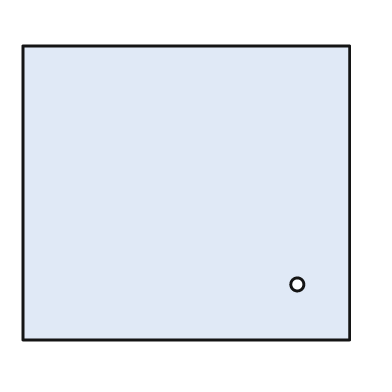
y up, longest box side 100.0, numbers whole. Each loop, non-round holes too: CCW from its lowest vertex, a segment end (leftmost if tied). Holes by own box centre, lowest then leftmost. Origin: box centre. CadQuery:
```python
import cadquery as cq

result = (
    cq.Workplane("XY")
    .moveTo(-50.0, -45.0)
    .lineTo(50.0, -45.0)
    .lineTo(50.0, 45.0)
    .lineTo(-50.0, 45.0)
    .close()
    .moveTo(34.0, -28.0)
    .circle(2.0)
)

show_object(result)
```